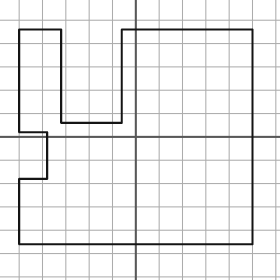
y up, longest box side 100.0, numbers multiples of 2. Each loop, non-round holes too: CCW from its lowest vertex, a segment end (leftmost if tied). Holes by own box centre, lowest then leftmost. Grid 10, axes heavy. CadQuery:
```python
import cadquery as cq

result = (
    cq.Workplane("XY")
    .moveTo(-50.0, -46.0)
    .lineTo(50.0, -46.0)
    .lineTo(50.0, 46.0)
    .lineTo(-6.0, 46.0)
    .lineTo(-6.0, 6.0)
    .lineTo(-32.0, 6.0)
    .lineTo(-32.0, 46.0)
    .lineTo(-50.0, 46.0)
    .lineTo(-50.0, 2.0)
    .lineTo(-38.0, 2.0)
    .lineTo(-38.0, -18.0)
    .lineTo(-50.0, -18.0)
    .close()
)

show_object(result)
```